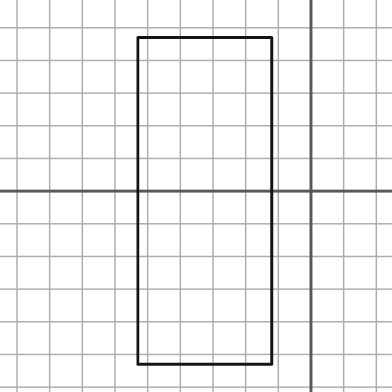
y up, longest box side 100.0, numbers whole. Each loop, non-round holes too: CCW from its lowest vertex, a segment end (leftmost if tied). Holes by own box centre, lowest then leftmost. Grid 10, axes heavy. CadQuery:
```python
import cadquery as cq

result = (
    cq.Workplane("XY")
    .moveTo(-53.0, -53.0)
    .lineTo(-12.0, -53.0)
    .lineTo(-12.0, 47.0)
    .lineTo(-53.0, 47.0)
    .close()
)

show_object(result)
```